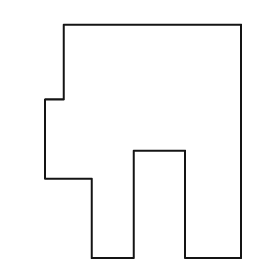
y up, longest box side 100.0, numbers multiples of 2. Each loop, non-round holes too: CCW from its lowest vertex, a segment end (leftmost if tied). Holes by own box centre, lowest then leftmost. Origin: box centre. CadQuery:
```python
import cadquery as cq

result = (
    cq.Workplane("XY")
    .moveTo(-22.0, -50.0)
    .lineTo(-4.0, -50.0)
    .lineTo(-4.0, -4.0)
    .lineTo(18.0, -4.0)
    .lineTo(18.0, -50.0)
    .lineTo(42.0, -50.0)
    .lineTo(42.0, 50.0)
    .lineTo(-34.0, 50.0)
    .lineTo(-34.0, 18.0)
    .lineTo(-42.0, 18.0)
    .lineTo(-42.0, -16.0)
    .lineTo(-22.0, -16.0)
    .close()
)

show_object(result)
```